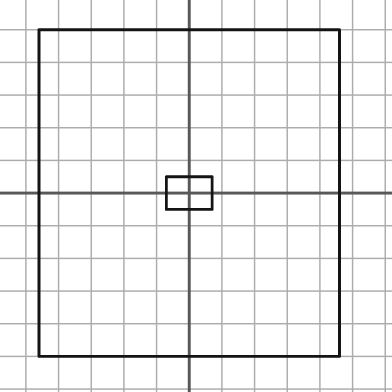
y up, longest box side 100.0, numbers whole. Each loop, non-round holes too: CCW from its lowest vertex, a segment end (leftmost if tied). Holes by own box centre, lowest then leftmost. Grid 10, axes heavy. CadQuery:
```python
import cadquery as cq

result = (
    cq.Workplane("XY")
    .moveTo(-46.0, -50.0)
    .lineTo(46.0, -50.0)
    .lineTo(46.0, 50.0)
    .lineTo(-46.0, 50.0)
    .close()
    .moveTo(-7.0, -5.0)
    .lineTo(7.0, -5.0)
    .lineTo(7.0, 5.0)
    .lineTo(-7.0, 5.0)
    .close()
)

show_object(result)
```